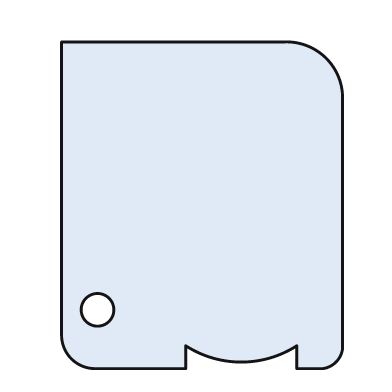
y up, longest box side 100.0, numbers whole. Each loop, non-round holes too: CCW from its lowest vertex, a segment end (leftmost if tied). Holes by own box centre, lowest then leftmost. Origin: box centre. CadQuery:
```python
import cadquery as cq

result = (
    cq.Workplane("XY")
    .moveTo(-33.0, -50.0)
    .lineTo(-5.0, -50.0)
    .lineTo(-5.0, -43.0)
    .threePointArc((12.0, -48.0), (29.0, -43.0))
    .lineTo(29.0, -50.0)
    .lineTo(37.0, -50.0)
    .threePointArc((41.0, -48.0), (43.0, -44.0))
    .lineTo(43.0, 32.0)
    .threePointArc((38.0, 45.0), (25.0, 50.0))
    .lineTo(-43.0, 50.0)
    .lineTo(-43.0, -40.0)
    .threePointArc((-40.0, -47.0), (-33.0, -50.0))
    .close()
    .moveTo(-32.0, -32.0)
    .circle(5.0)
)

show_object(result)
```